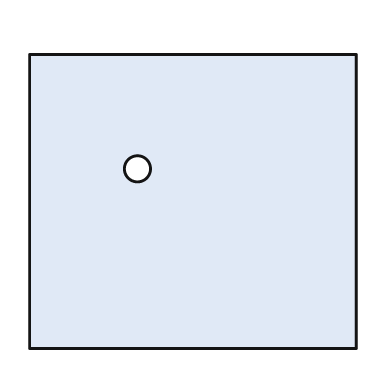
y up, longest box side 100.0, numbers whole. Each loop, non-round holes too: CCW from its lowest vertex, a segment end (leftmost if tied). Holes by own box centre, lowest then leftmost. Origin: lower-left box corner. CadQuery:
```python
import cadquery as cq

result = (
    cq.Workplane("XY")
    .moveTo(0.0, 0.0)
    .lineTo(100.0, 0.0)
    .lineTo(100.0, 90.0)
    .lineTo(0.0, 90.0)
    .close()
    .moveTo(33.0, 55.0)
    .circle(4.0)
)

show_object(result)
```